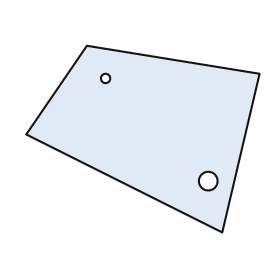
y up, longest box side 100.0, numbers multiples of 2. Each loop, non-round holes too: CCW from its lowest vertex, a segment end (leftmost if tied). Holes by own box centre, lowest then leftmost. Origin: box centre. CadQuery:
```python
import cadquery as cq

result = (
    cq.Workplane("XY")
    .moveTo(34.0, -40.0)
    .lineTo(50.0, 28.0)
    .lineTo(-24.0, 40.0)
    .lineTo(-50.0, 2.0)
    .close()
    .moveTo(28.0, -18.0)
    .circle(4.0)
    .moveTo(-16.0, 26.0)
    .circle(2.0)
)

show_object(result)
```